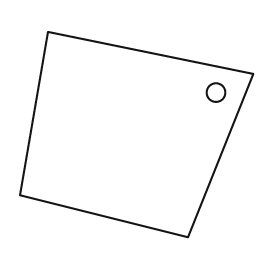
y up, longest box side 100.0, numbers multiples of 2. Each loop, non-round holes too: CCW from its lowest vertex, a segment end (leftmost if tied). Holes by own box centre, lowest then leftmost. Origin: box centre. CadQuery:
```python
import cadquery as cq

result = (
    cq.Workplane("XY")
    .moveTo(22.0, -44.0)
    .lineTo(50.0, 26.0)
    .lineTo(-38.0, 44.0)
    .lineTo(-50.0, -26.0)
    .close()
    .moveTo(34.0, 18.0)
    .circle(4.0)
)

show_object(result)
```